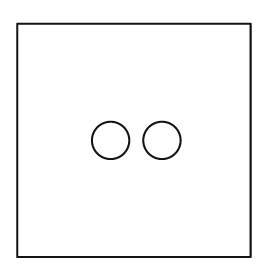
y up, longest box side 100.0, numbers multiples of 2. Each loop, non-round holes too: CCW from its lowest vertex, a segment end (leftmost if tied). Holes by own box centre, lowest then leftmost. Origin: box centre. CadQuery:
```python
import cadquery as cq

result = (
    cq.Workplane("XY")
    .moveTo(-50.0, -50.0)
    .lineTo(50.0, -50.0)
    .lineTo(50.0, 50.0)
    .lineTo(-50.0, 50.0)
    .close()
    .moveTo(-10.0, 0.0)
    .circle(8.0)
    .moveTo(12.0, 0.0)
    .circle(8.0)
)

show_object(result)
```